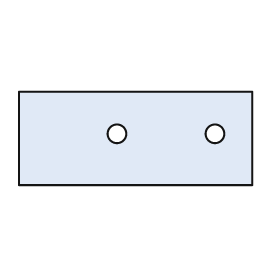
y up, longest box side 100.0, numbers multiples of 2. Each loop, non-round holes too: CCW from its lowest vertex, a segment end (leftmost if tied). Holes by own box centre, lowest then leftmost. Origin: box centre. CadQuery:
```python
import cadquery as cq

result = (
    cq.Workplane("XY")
    .moveTo(-50.0, -20.0)
    .lineTo(50.0, -20.0)
    .lineTo(50.0, 20.0)
    .lineTo(-50.0, 20.0)
    .close()
    .moveTo(-8.0, 2.0)
    .circle(4.0)
    .moveTo(34.0, 2.0)
    .circle(4.0)
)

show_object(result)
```